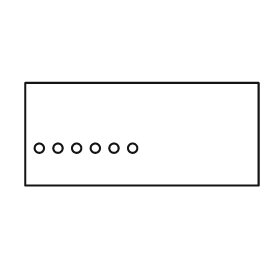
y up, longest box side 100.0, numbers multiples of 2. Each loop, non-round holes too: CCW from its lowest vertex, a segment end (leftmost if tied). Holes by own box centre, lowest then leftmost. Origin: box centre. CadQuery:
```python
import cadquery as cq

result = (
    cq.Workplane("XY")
    .moveTo(-50.0, -22.0)
    .lineTo(50.0, -22.0)
    .lineTo(50.0, 22.0)
    .lineTo(-50.0, 22.0)
    .close()
    .moveTo(-44.0, -6.0)
    .circle(2.0)
    .moveTo(-36.0, -6.0)
    .circle(2.0)
    .moveTo(-28.0, -6.0)
    .circle(2.0)
    .moveTo(-20.0, -6.0)
    .circle(2.0)
    .moveTo(-12.0, -6.0)
    .circle(2.0)
    .moveTo(-4.0, -6.0)
    .circle(2.0)
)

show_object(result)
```